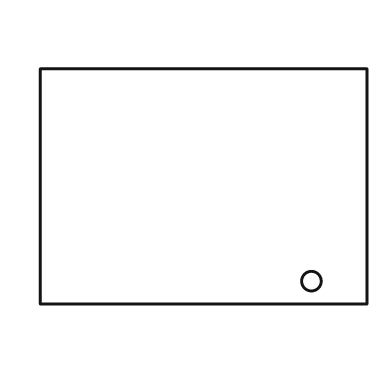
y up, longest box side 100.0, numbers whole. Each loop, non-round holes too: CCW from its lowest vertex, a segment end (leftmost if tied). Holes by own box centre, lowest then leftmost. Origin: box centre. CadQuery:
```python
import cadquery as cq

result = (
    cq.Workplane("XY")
    .moveTo(-50.0, -36.0)
    .lineTo(50.0, -36.0)
    .lineTo(50.0, 36.0)
    .lineTo(-50.0, 36.0)
    .close()
    .moveTo(33.0, -29.0)
    .circle(3.0)
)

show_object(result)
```